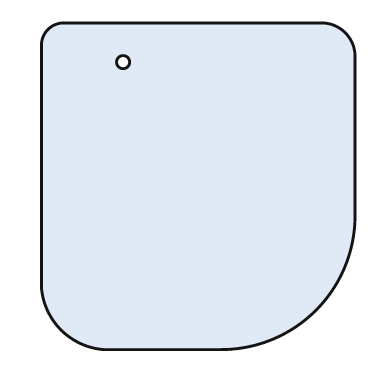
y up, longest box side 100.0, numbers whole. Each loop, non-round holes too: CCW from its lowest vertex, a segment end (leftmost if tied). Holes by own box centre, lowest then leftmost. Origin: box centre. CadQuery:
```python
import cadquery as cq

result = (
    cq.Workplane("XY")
    .moveTo(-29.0, -50.0)
    .lineTo(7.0, -50.0)
    .threePointArc((36.0, -38.0), (48.0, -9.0))
    .lineTo(48.0, 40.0)
    .threePointArc((45.0, 47.0), (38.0, 50.0))
    .lineTo(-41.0, 50.0)
    .threePointArc((-46.0, 48.0), (-48.0, 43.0))
    .lineTo(-48.0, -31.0)
    .threePointArc((-42.0, -44.0), (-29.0, -50.0))
    .close()
    .moveTo(-23.0, 38.0)
    .circle(2.0)
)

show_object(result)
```